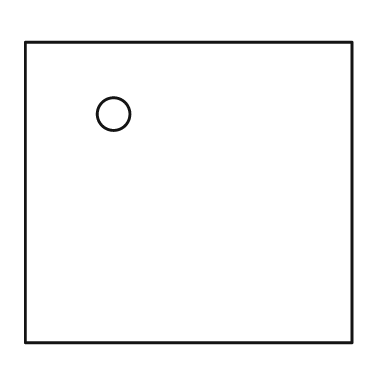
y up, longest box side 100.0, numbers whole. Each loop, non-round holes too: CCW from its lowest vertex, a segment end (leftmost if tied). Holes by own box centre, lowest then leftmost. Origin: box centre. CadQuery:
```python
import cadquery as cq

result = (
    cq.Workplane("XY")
    .moveTo(-50.0, -46.0)
    .lineTo(50.0, -46.0)
    .lineTo(50.0, 46.0)
    .lineTo(-50.0, 46.0)
    .close()
    .moveTo(-23.0, 24.0)
    .circle(5.0)
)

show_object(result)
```